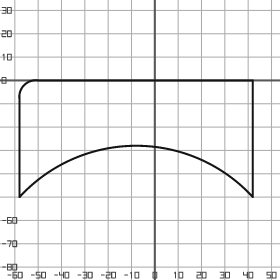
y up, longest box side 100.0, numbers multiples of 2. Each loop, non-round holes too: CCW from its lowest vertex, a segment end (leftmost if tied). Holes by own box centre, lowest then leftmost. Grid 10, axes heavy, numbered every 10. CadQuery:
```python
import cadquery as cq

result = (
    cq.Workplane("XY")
    .moveTo(-58.0, -50.0)
    .threePointArc((-8.0, -28.0), (42.0, -50.0))
    .lineTo(42.0, 0.0)
    .lineTo(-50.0, 0.0)
    .threePointArc((-56.0, -2.0), (-58.0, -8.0))
    .close()
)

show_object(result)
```